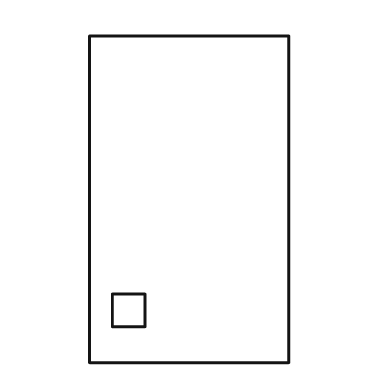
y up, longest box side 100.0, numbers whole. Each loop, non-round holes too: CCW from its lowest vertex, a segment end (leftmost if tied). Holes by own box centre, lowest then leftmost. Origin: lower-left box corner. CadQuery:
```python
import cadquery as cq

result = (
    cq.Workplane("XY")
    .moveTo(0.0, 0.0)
    .lineTo(61.0, 0.0)
    .lineTo(61.0, 100.0)
    .lineTo(0.0, 100.0)
    .close()
    .moveTo(7.0, 11.0)
    .lineTo(17.0, 11.0)
    .lineTo(17.0, 21.0)
    .lineTo(7.0, 21.0)
    .close()
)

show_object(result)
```